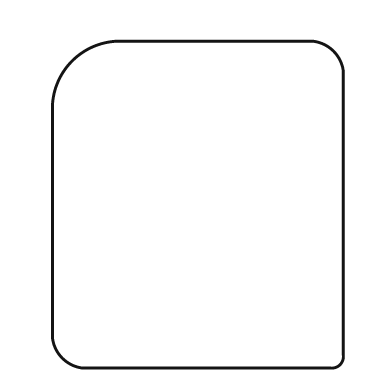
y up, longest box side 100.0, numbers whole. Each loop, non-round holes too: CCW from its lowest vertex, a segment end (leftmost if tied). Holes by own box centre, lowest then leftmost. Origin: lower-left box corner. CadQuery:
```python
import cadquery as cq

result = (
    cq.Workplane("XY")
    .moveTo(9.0, 0.0)
    .lineTo(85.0, 0.0)
    .threePointArc((88.0, 1.0), (89.0, 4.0))
    .lineTo(89.0, 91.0)
    .threePointArc((86.0, 97.0), (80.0, 100.0))
    .lineTo(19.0, 100.0)
    .threePointArc((6.0, 94.0), (0.0, 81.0))
    .lineTo(0.0, 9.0)
    .threePointArc((3.0, 3.0), (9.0, 0.0))
    .close()
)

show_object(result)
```